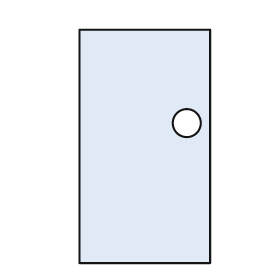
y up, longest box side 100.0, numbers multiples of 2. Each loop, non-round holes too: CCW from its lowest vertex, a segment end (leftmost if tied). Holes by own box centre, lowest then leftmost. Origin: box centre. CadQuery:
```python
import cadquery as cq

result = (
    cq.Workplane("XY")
    .moveTo(-28.0, -50.0)
    .lineTo(28.0, -50.0)
    .lineTo(28.0, 50.0)
    .lineTo(-28.0, 50.0)
    .close()
    .moveTo(18.0, 10.0)
    .circle(6.0)
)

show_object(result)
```